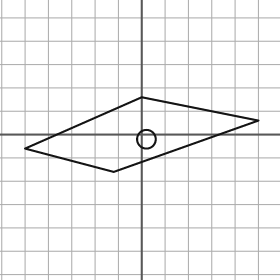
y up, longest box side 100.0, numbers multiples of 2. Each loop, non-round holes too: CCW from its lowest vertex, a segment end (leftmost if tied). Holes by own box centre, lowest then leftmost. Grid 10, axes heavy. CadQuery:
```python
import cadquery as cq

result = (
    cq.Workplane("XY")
    .moveTo(-12.0, -16.0)
    .lineTo(50.0, 6.0)
    .lineTo(0.0, 16.0)
    .lineTo(-50.0, -6.0)
    .close()
    .moveTo(2.0, -2.0)
    .circle(4.0)
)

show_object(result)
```